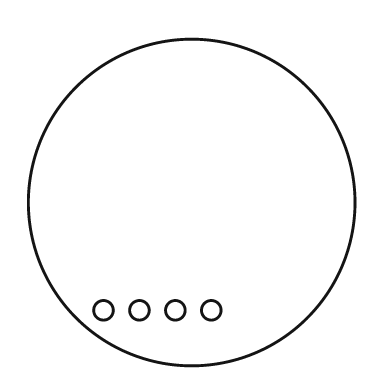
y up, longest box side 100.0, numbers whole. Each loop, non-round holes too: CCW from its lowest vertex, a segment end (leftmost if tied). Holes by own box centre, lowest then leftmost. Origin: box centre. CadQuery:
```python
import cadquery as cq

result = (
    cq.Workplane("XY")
    .moveTo(0.0, 0.0)
    .circle(50.0)
    .moveTo(-27.0, -33.0)
    .circle(3.0)
    .moveTo(-16.0, -33.0)
    .circle(3.0)
    .moveTo(-5.0, -33.0)
    .circle(3.0)
    .moveTo(6.0, -33.0)
    .circle(3.0)
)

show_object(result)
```